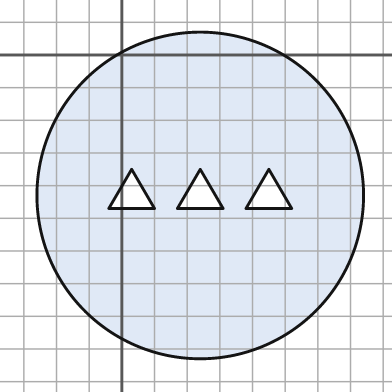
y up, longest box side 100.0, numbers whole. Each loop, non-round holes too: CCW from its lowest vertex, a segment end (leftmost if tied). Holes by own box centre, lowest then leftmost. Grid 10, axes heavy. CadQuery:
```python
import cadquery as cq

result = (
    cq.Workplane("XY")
    .moveTo(24.0, -43.0)
    .circle(50.0)
    .moveTo(-4.0, -47.0)
    .lineTo(10.0, -47.0)
    .lineTo(3.0, -35.0)
    .close()
    .moveTo(17.0, -47.0)
    .lineTo(31.0, -47.0)
    .lineTo(24.0, -35.0)
    .close()
    .moveTo(38.0, -47.0)
    .lineTo(52.0, -47.0)
    .lineTo(45.0, -35.0)
    .close()
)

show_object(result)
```